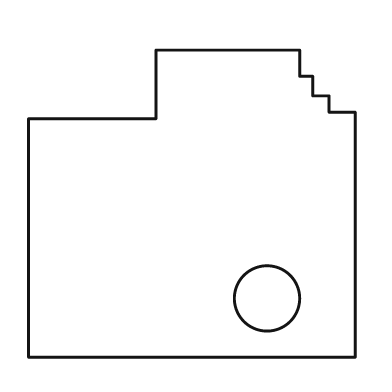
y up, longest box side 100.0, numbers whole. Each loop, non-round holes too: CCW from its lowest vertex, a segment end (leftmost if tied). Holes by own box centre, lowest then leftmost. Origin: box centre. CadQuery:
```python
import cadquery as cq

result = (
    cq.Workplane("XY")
    .moveTo(-50.0, -47.0)
    .lineTo(50.0, -47.0)
    .lineTo(50.0, 28.0)
    .lineTo(42.0, 28.0)
    .lineTo(42.0, 33.0)
    .lineTo(37.0, 33.0)
    .lineTo(37.0, 39.0)
    .lineTo(33.0, 39.0)
    .lineTo(33.0, 47.0)
    .lineTo(-11.0, 47.0)
    .lineTo(-11.0, 26.0)
    .lineTo(-50.0, 26.0)
    .close()
    .moveTo(23.0, -29.0)
    .circle(10.0)
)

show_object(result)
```